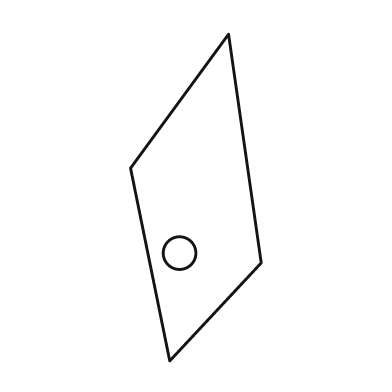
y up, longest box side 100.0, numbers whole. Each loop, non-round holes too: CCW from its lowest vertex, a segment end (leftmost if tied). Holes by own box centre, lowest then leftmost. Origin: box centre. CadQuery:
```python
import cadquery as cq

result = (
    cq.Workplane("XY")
    .moveTo(-8.0, -50.0)
    .lineTo(20.0, -20.0)
    .lineTo(10.0, 50.0)
    .lineTo(-20.0, 9.0)
    .close()
    .moveTo(-5.0, -17.0)
    .circle(5.0)
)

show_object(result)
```